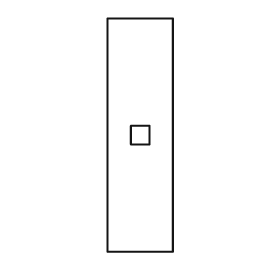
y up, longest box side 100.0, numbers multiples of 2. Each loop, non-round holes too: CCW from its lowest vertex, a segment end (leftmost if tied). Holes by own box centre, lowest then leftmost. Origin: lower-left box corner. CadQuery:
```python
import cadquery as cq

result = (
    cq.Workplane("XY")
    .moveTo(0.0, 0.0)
    .lineTo(28.0, 0.0)
    .lineTo(28.0, 100.0)
    .lineTo(0.0, 100.0)
    .close()
    .moveTo(10.0, 46.0)
    .lineTo(18.0, 46.0)
    .lineTo(18.0, 54.0)
    .lineTo(10.0, 54.0)
    .close()
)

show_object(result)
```